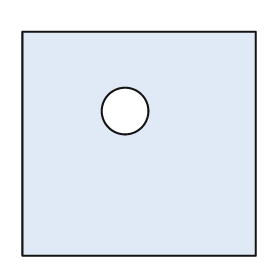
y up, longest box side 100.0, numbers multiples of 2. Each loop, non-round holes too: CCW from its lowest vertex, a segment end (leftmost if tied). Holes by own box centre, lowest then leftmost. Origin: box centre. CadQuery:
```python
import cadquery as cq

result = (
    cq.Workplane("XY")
    .moveTo(-50.0, -48.0)
    .lineTo(50.0, -48.0)
    .lineTo(50.0, 48.0)
    .lineTo(-50.0, 48.0)
    .close()
    .moveTo(-6.0, 14.0)
    .circle(10.0)
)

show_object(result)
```